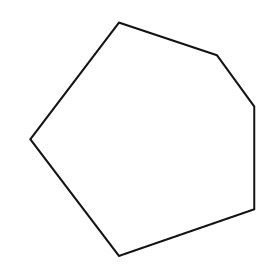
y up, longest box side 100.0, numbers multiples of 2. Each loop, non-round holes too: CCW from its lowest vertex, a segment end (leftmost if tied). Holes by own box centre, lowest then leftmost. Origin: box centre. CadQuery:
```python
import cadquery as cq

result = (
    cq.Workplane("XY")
    .moveTo(-10.0, -50.0)
    .lineTo(48.0, -30.0)
    .lineTo(48.0, 14.0)
    .lineTo(32.0, 36.0)
    .lineTo(-10.0, 50.0)
    .lineTo(-48.0, 0.0)
    .close()
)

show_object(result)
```